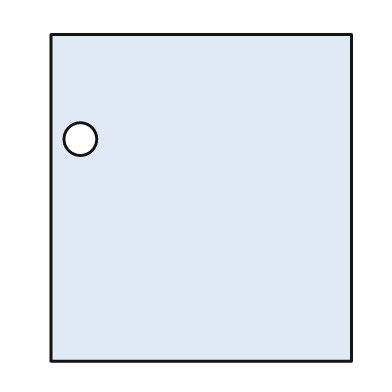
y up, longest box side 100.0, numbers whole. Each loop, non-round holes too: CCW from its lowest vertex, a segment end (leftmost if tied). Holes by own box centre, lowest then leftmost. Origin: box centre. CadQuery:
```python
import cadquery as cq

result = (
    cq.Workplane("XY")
    .moveTo(-46.0, -50.0)
    .lineTo(46.0, -50.0)
    .lineTo(46.0, 50.0)
    .lineTo(-46.0, 50.0)
    .close()
    .moveTo(-37.0, 18.0)
    .circle(5.0)
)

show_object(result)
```